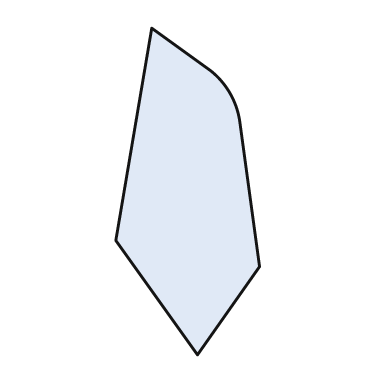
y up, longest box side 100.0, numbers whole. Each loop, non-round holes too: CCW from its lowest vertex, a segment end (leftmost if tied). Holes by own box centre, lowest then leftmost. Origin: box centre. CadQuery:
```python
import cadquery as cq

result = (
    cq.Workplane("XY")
    .moveTo(3.0, -50.0)
    .lineTo(22.0, -23.0)
    .lineTo(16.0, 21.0)
    .threePointArc((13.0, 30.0), (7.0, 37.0))
    .lineTo(-11.0, 50.0)
    .lineTo(-22.0, -15.0)
    .close()
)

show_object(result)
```